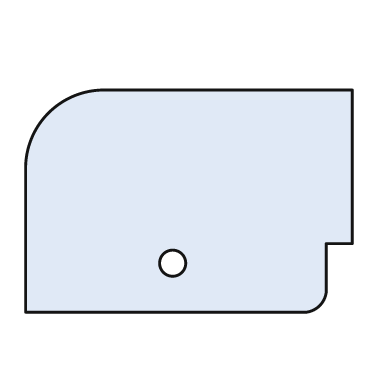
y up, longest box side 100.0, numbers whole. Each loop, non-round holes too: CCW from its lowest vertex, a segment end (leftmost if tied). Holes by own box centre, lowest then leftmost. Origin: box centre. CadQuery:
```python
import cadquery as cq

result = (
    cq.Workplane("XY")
    .moveTo(-50.0, -34.0)
    .lineTo(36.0, -34.0)
    .threePointArc((40.0, -32.0), (42.0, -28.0))
    .lineTo(42.0, -13.0)
    .lineTo(50.0, -13.0)
    .lineTo(50.0, 34.0)
    .lineTo(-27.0, 34.0)
    .threePointArc((-43.0, 27.0), (-50.0, 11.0))
    .close()
    .moveTo(-5.0, -19.0)
    .circle(4.0)
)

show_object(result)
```